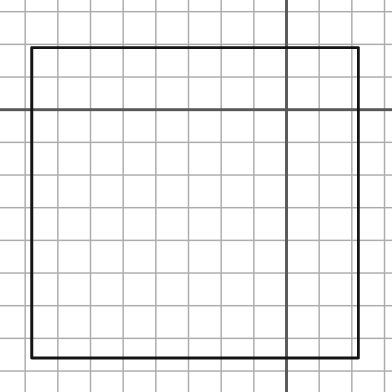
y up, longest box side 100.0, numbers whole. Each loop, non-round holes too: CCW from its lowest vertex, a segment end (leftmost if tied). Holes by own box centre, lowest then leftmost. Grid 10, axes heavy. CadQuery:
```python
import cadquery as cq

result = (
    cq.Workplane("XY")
    .moveTo(-78.0, -76.0)
    .lineTo(22.0, -76.0)
    .lineTo(22.0, 19.0)
    .lineTo(-78.0, 19.0)
    .close()
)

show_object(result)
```